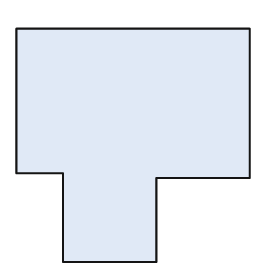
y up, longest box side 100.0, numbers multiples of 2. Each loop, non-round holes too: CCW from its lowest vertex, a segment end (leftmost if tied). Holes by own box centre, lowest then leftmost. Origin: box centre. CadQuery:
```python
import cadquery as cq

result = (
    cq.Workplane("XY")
    .moveTo(-30.0, -50.0)
    .lineTo(10.0, -50.0)
    .lineTo(10.0, -14.0)
    .lineTo(50.0, -14.0)
    .lineTo(50.0, 50.0)
    .lineTo(-50.0, 50.0)
    .lineTo(-50.0, -12.0)
    .lineTo(-30.0, -12.0)
    .close()
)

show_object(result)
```